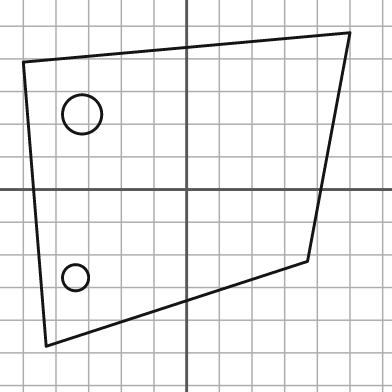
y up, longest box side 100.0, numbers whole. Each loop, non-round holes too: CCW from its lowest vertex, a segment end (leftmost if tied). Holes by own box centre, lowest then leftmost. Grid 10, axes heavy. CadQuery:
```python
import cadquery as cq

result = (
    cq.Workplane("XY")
    .moveTo(-43.0, -48.0)
    .lineTo(37.0, -22.0)
    .lineTo(50.0, 48.0)
    .lineTo(-50.0, 39.0)
    .close()
    .moveTo(-34.0, -27.0)
    .circle(4.0)
    .moveTo(-32.0, 23.0)
    .circle(6.0)
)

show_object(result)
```